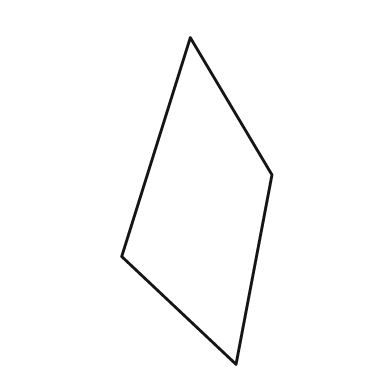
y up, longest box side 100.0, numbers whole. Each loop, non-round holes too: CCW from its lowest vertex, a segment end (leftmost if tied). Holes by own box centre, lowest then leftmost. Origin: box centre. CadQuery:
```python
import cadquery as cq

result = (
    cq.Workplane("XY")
    .moveTo(12.0, -50.0)
    .lineTo(23.0, 8.0)
    .lineTo(-2.0, 50.0)
    .lineTo(-23.0, -17.0)
    .close()
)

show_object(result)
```